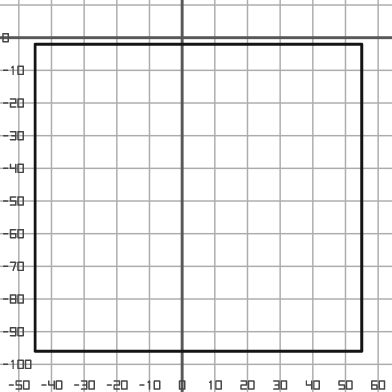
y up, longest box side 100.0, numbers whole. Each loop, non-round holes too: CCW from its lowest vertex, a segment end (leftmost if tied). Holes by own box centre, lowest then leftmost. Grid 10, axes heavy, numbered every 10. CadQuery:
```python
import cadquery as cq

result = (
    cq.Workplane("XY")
    .moveTo(-45.0, -96.0)
    .lineTo(55.0, -96.0)
    .lineTo(55.0, -2.0)
    .lineTo(-45.0, -2.0)
    .close()
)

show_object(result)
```